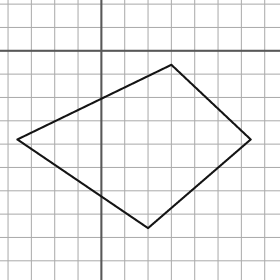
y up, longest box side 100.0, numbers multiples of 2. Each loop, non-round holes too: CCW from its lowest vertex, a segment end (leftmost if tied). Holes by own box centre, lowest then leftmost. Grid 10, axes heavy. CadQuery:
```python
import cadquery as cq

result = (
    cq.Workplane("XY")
    .moveTo(20.0, -76.0)
    .lineTo(64.0, -38.0)
    .lineTo(30.0, -6.0)
    .lineTo(-36.0, -38.0)
    .close()
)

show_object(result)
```